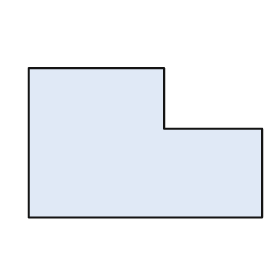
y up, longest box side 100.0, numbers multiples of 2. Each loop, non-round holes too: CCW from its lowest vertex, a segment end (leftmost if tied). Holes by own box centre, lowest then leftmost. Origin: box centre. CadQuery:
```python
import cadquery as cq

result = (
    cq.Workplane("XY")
    .moveTo(-50.0, -32.0)
    .lineTo(50.0, -32.0)
    .lineTo(50.0, 6.0)
    .lineTo(8.0, 6.0)
    .lineTo(8.0, 32.0)
    .lineTo(-50.0, 32.0)
    .close()
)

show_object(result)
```